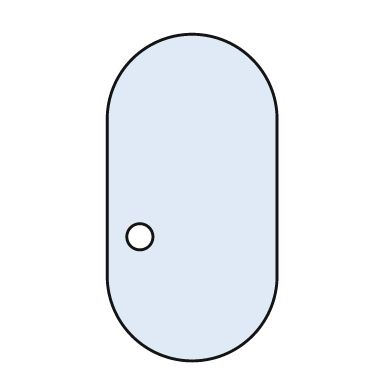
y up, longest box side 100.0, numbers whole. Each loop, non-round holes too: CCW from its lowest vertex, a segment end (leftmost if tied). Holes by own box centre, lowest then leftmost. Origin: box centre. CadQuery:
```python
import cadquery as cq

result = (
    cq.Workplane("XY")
    .moveTo(-26.0, -24.0)
    .threePointArc((0.0, -50.0), (26.0, -24.0))
    .lineTo(26.0, 24.0)
    .threePointArc((0.0, 50.0), (-26.0, 24.0))
    .close()
    .moveTo(-16.0, -12.0)
    .circle(4.0)
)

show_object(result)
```